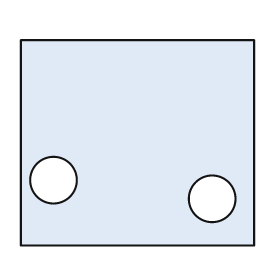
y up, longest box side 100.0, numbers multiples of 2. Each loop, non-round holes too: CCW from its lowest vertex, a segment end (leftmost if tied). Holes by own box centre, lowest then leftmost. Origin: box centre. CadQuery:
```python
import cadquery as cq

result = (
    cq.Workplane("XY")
    .moveTo(-50.0, -44.0)
    .lineTo(50.0, -44.0)
    .lineTo(50.0, 44.0)
    .lineTo(-50.0, 44.0)
    .close()
    .moveTo(32.0, -24.0)
    .circle(10.0)
    .moveTo(-36.0, -16.0)
    .circle(10.0)
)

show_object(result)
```